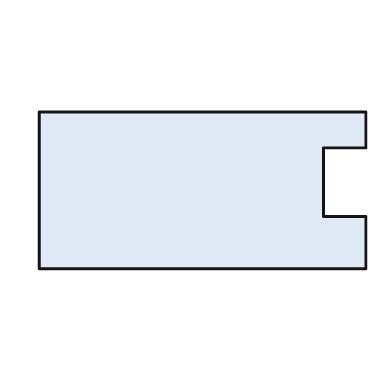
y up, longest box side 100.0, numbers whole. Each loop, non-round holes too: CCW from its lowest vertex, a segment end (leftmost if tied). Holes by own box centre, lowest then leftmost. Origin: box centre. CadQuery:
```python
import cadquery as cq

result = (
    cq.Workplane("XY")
    .moveTo(-50.0, -24.0)
    .lineTo(50.0, -24.0)
    .lineTo(50.0, -8.0)
    .lineTo(37.0, -8.0)
    .lineTo(37.0, 13.0)
    .lineTo(50.0, 13.0)
    .lineTo(50.0, 24.0)
    .lineTo(-50.0, 24.0)
    .close()
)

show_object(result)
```